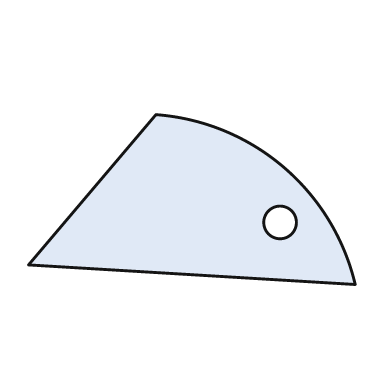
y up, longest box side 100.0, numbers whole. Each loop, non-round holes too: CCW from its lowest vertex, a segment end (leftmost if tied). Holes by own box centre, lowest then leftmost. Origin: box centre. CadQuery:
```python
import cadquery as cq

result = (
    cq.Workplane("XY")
    .moveTo(50.0, -26.0)
    .threePointArc((28.0, 10.0), (-11.0, 26.0))
    .lineTo(-50.0, -20.0)
    .close()
    .moveTo(27.0, -7.0)
    .circle(5.0)
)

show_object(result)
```